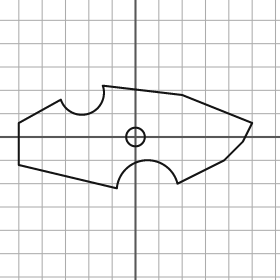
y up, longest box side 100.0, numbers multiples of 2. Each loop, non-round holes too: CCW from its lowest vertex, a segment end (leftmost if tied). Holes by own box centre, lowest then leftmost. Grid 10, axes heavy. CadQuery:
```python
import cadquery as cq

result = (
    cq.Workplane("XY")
    .moveTo(-8.0, -22.0)
    .threePointArc((4.0, -10.0), (18.0, -20.0))
    .lineTo(38.0, -10.0)
    .lineTo(46.0, -2.0)
    .lineTo(50.0, 6.0)
    .lineTo(20.0, 18.0)
    .lineTo(-14.0, 22.0)
    .threePointArc((-20.0, 10.0), (-32.0, 16.0))
    .lineTo(-50.0, 6.0)
    .lineTo(-50.0, -12.0)
    .close()
    .moveTo(0.0, 0.0)
    .circle(4.0)
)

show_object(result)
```